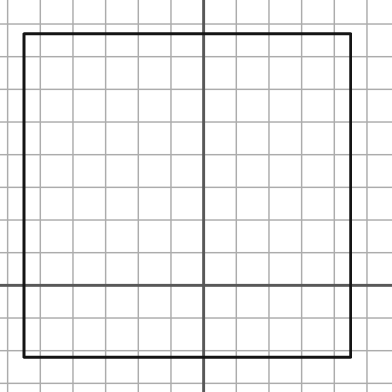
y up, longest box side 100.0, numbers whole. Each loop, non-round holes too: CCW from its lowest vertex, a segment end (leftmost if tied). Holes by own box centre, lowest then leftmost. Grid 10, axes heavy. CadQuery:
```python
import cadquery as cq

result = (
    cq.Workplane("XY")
    .moveTo(-55.0, -22.0)
    .lineTo(45.0, -22.0)
    .lineTo(45.0, 77.0)
    .lineTo(-55.0, 77.0)
    .close()
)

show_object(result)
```